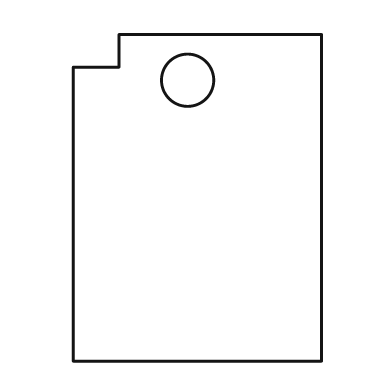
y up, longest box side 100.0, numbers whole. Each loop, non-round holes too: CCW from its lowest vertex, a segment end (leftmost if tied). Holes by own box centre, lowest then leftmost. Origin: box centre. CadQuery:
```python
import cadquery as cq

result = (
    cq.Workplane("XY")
    .moveTo(-38.0, -50.0)
    .lineTo(38.0, -50.0)
    .lineTo(38.0, 50.0)
    .lineTo(-24.0, 50.0)
    .lineTo(-24.0, 40.0)
    .lineTo(-38.0, 40.0)
    .close()
    .moveTo(-3.0, 36.0)
    .circle(8.0)
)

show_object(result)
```